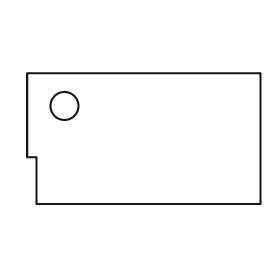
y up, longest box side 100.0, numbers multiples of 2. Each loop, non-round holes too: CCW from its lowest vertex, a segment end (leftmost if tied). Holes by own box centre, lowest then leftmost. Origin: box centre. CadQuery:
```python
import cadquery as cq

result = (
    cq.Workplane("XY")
    .moveTo(-46.0, -28.0)
    .lineTo(50.0, -28.0)
    .lineTo(50.0, 28.0)
    .lineTo(-50.0, 28.0)
    .lineTo(-50.0, -8.0)
    .lineTo(-46.0, -8.0)
    .close()
    .moveTo(-34.0, 14.0)
    .circle(6.0)
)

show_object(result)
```